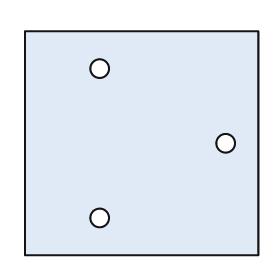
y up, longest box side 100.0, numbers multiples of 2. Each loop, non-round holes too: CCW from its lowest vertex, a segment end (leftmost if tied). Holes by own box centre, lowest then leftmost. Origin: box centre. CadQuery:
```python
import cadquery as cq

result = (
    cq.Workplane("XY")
    .moveTo(-50.0, -48.0)
    .lineTo(50.0, -48.0)
    .lineTo(50.0, 48.0)
    .lineTo(-50.0, 48.0)
    .close()
    .moveTo(-18.0, -32.0)
    .circle(4.0)
    .moveTo(36.0, 0.0)
    .circle(4.0)
    .moveTo(-18.0, 32.0)
    .circle(4.0)
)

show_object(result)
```